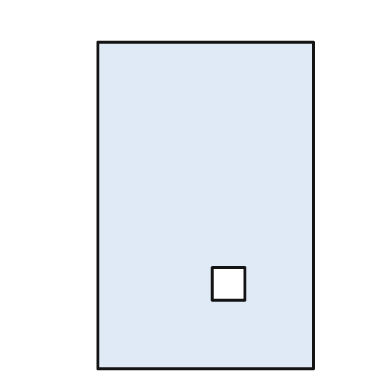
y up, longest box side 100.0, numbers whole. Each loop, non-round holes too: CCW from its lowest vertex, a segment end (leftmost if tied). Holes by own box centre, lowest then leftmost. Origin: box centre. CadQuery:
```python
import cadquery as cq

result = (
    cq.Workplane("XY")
    .moveTo(-33.0, -50.0)
    .lineTo(33.0, -50.0)
    .lineTo(33.0, 50.0)
    .lineTo(-33.0, 50.0)
    .close()
    .moveTo(2.0, -29.0)
    .lineTo(12.0, -29.0)
    .lineTo(12.0, -19.0)
    .lineTo(2.0, -19.0)
    .close()
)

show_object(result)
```